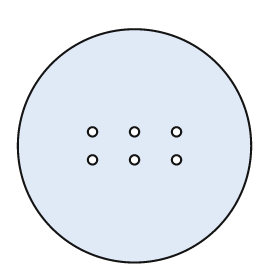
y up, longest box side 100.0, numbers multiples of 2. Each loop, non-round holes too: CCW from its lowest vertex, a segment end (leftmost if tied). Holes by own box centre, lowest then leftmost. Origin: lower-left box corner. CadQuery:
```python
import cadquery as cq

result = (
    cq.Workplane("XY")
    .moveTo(50.0, 50.0)
    .circle(50.0)
    .moveTo(32.0, 44.0)
    .circle(2.0)
    .moveTo(50.0, 44.0)
    .circle(2.0)
    .moveTo(68.0, 44.0)
    .circle(2.0)
    .moveTo(32.0, 56.0)
    .circle(2.0)
    .moveTo(50.0, 56.0)
    .circle(2.0)
    .moveTo(68.0, 56.0)
    .circle(2.0)
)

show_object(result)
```